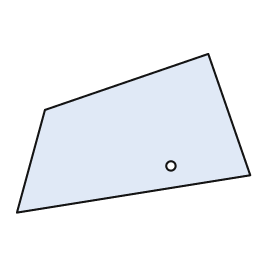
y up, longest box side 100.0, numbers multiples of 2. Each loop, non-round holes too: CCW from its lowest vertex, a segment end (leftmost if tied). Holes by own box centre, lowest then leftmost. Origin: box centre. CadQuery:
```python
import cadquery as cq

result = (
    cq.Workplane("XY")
    .moveTo(-50.0, -34.0)
    .lineTo(50.0, -18.0)
    .lineTo(32.0, 34.0)
    .lineTo(-38.0, 10.0)
    .close()
    .moveTo(16.0, -14.0)
    .circle(2.0)
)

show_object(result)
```